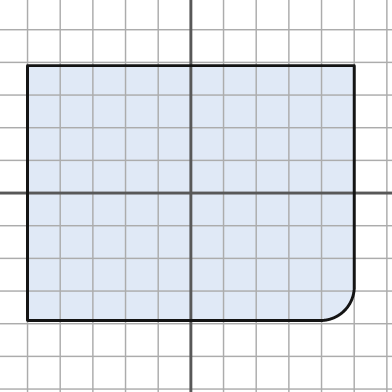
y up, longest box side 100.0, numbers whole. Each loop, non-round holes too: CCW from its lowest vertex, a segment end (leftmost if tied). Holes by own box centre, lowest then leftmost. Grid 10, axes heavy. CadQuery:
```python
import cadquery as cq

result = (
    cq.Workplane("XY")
    .moveTo(-50.0, -39.0)
    .lineTo(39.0, -39.0)
    .threePointArc((47.0, -36.0), (50.0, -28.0))
    .lineTo(50.0, 39.0)
    .lineTo(-50.0, 39.0)
    .close()
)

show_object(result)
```